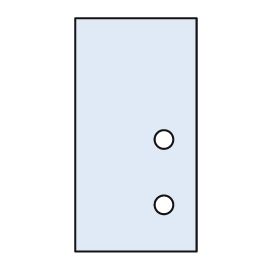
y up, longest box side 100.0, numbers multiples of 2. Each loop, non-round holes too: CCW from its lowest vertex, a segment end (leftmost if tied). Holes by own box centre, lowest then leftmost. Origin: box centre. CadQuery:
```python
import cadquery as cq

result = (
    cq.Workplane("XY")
    .moveTo(-26.0, -50.0)
    .lineTo(26.0, -50.0)
    .lineTo(26.0, 50.0)
    .lineTo(-26.0, 50.0)
    .close()
    .moveTo(12.0, -30.0)
    .circle(4.0)
    .moveTo(12.0, -2.0)
    .circle(4.0)
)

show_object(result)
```